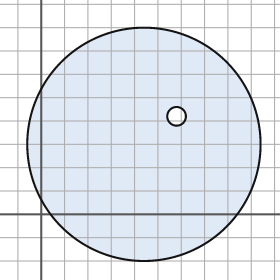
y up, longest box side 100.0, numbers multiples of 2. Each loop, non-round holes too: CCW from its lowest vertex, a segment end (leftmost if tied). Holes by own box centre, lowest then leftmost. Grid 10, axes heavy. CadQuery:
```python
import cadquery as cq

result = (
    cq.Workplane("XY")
    .moveTo(44.0, 30.0)
    .circle(50.0)
    .moveTo(58.0, 42.0)
    .circle(4.0)
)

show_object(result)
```